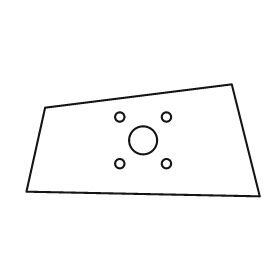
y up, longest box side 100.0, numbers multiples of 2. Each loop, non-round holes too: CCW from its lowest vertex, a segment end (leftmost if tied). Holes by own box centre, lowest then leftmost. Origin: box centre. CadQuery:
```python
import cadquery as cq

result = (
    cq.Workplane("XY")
    .moveTo(50.0, -24.0)
    .lineTo(38.0, 24.0)
    .lineTo(-42.0, 14.0)
    .lineTo(-50.0, -22.0)
    .close()
    .moveTo(-10.0, -10.0)
    .circle(2.0)
    .moveTo(10.0, -10.0)
    .circle(2.0)
    .moveTo(0.0, 0.0)
    .circle(6.0)
    .moveTo(-10.0, 10.0)
    .circle(2.0)
    .moveTo(10.0, 10.0)
    .circle(2.0)
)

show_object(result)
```